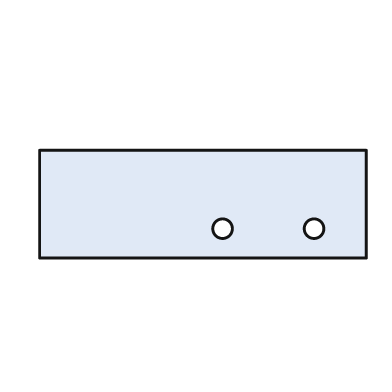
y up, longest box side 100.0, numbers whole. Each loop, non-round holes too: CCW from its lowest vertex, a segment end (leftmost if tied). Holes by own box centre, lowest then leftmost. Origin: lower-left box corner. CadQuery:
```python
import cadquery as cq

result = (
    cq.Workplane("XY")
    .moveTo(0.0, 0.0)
    .lineTo(100.0, 0.0)
    .lineTo(100.0, 33.0)
    .lineTo(0.0, 33.0)
    .close()
    .moveTo(56.0, 9.0)
    .circle(3.0)
    .moveTo(84.0, 9.0)
    .circle(3.0)
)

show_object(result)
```